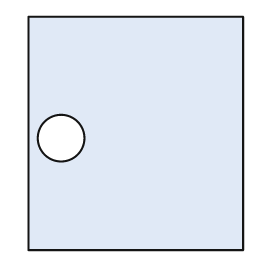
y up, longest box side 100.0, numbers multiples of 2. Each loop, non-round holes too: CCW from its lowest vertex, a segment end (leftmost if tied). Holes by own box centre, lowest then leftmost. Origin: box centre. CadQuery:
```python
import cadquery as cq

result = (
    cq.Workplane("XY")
    .moveTo(-46.0, -50.0)
    .lineTo(46.0, -50.0)
    .lineTo(46.0, 50.0)
    .lineTo(-46.0, 50.0)
    .close()
    .moveTo(-32.0, -2.0)
    .circle(10.0)
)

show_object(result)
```